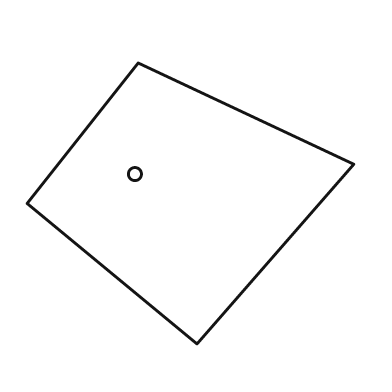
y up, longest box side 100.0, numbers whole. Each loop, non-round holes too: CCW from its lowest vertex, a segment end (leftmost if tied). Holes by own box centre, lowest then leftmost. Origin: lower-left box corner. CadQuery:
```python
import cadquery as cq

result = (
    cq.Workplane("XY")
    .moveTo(52.0, 0.0)
    .lineTo(100.0, 55.0)
    .lineTo(34.0, 86.0)
    .lineTo(0.0, 43.0)
    .close()
    .moveTo(33.0, 52.0)
    .circle(2.0)
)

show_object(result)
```